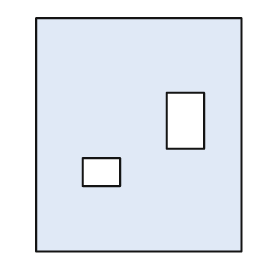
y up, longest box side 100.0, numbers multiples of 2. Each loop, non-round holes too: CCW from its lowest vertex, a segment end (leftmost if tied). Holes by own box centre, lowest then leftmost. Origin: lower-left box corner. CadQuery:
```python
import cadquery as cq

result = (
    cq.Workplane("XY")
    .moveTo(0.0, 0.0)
    .lineTo(88.0, 0.0)
    .lineTo(88.0, 100.0)
    .lineTo(0.0, 100.0)
    .close()
    .moveTo(20.0, 28.0)
    .lineTo(36.0, 28.0)
    .lineTo(36.0, 40.0)
    .lineTo(20.0, 40.0)
    .close()
    .moveTo(56.0, 44.0)
    .lineTo(72.0, 44.0)
    .lineTo(72.0, 68.0)
    .lineTo(56.0, 68.0)
    .close()
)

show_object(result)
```